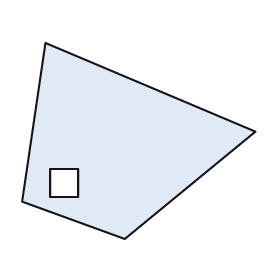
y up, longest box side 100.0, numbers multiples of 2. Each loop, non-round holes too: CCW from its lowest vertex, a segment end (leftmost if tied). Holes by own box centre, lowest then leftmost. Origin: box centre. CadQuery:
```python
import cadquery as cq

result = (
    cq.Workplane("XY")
    .moveTo(-6.0, -42.0)
    .lineTo(50.0, 4.0)
    .lineTo(-40.0, 42.0)
    .lineTo(-50.0, -26.0)
    .close()
    .moveTo(-38.0, -24.0)
    .lineTo(-26.0, -24.0)
    .lineTo(-26.0, -12.0)
    .lineTo(-38.0, -12.0)
    .close()
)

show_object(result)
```